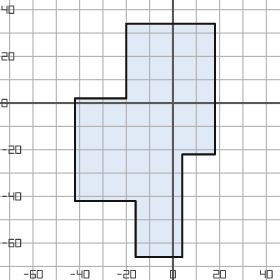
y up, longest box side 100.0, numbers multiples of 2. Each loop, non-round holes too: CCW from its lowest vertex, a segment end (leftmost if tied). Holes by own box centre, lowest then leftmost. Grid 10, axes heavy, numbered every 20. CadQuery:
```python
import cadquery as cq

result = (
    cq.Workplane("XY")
    .moveTo(-16.0, -66.0)
    .lineTo(4.0, -66.0)
    .lineTo(4.0, -22.0)
    .lineTo(18.0, -22.0)
    .lineTo(18.0, 34.0)
    .lineTo(-20.0, 34.0)
    .lineTo(-20.0, 2.0)
    .lineTo(-42.0, 2.0)
    .lineTo(-42.0, -42.0)
    .lineTo(-16.0, -42.0)
    .close()
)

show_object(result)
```